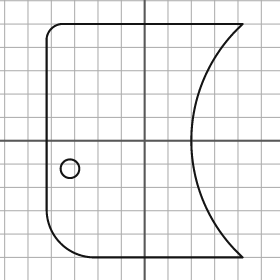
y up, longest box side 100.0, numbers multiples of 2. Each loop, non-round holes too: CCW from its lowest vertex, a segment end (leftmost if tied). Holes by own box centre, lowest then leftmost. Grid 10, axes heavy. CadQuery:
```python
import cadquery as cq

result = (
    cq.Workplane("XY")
    .moveTo(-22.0, -50.0)
    .lineTo(42.0, -50.0)
    .threePointArc((20.0, 0.0), (42.0, 50.0))
    .lineTo(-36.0, 50.0)
    .threePointArc((-40.0, 48.0), (-42.0, 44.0))
    .lineTo(-42.0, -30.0)
    .threePointArc((-36.0, -44.0), (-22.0, -50.0))
    .close()
    .moveTo(-32.0, -12.0)
    .circle(4.0)
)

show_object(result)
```